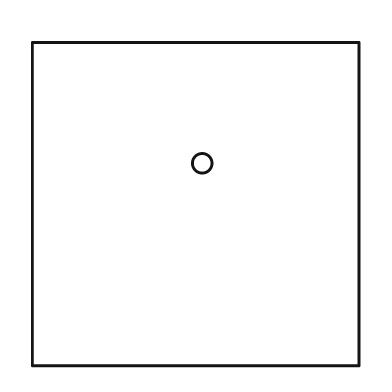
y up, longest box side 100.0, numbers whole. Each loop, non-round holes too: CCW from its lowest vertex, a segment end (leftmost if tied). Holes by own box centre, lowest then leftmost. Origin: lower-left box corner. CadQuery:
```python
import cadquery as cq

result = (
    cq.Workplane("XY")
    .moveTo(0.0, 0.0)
    .lineTo(100.0, 0.0)
    .lineTo(100.0, 99.0)
    .lineTo(0.0, 99.0)
    .close()
    .moveTo(52.0, 62.0)
    .circle(3.0)
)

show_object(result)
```